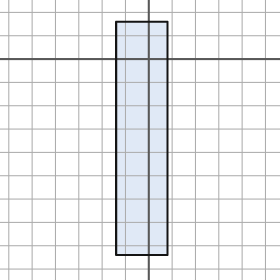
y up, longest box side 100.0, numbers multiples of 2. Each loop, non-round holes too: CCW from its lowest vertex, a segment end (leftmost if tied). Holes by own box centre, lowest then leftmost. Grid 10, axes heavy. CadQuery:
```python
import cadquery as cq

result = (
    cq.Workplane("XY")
    .moveTo(-14.0, -84.0)
    .lineTo(8.0, -84.0)
    .lineTo(8.0, 16.0)
    .lineTo(-14.0, 16.0)
    .close()
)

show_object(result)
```